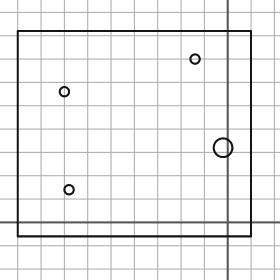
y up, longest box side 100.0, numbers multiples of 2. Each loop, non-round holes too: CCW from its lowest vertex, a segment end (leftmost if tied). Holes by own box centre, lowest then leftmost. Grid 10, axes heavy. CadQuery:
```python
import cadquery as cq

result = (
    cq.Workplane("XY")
    .moveTo(-90.0, -6.0)
    .lineTo(10.0, -6.0)
    .lineTo(10.0, 82.0)
    .lineTo(-90.0, 82.0)
    .close()
    .moveTo(-68.0, 14.0)
    .circle(2.0)
    .moveTo(-2.0, 32.0)
    .circle(4.0)
    .moveTo(-70.0, 56.0)
    .circle(2.0)
    .moveTo(-14.0, 70.0)
    .circle(2.0)
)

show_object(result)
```